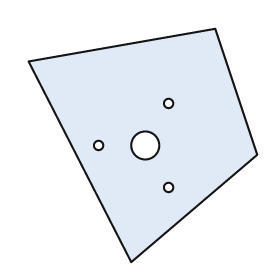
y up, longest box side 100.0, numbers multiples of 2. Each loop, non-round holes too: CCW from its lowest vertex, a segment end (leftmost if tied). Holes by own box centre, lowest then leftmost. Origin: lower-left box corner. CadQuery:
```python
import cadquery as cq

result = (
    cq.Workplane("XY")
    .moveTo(44.0, 0.0)
    .lineTo(98.0, 46.0)
    .lineTo(80.0, 100.0)
    .lineTo(0.0, 86.0)
    .close()
    .moveTo(60.0, 32.0)
    .circle(2.0)
    .moveTo(30.0, 50.0)
    .circle(2.0)
    .moveTo(50.0, 50.0)
    .circle(6.0)
    .moveTo(60.0, 68.0)
    .circle(2.0)
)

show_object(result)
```